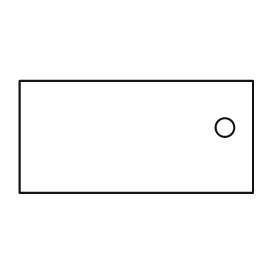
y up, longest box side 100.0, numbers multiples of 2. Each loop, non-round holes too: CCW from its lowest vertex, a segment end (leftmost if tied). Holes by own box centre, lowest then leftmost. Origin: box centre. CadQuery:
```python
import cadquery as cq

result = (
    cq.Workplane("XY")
    .moveTo(-50.0, -24.0)
    .lineTo(50.0, -24.0)
    .lineTo(50.0, 24.0)
    .lineTo(-50.0, 24.0)
    .close()
    .moveTo(38.0, 4.0)
    .circle(4.0)
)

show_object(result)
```